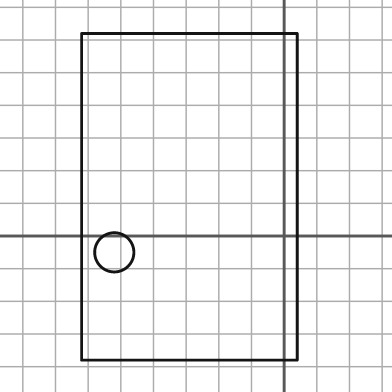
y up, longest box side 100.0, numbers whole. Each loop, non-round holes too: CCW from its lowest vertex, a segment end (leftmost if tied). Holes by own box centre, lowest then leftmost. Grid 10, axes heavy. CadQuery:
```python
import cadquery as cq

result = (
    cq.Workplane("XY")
    .moveTo(-62.0, -38.0)
    .lineTo(4.0, -38.0)
    .lineTo(4.0, 62.0)
    .lineTo(-62.0, 62.0)
    .close()
    .moveTo(-52.0, -5.0)
    .circle(6.0)
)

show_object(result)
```